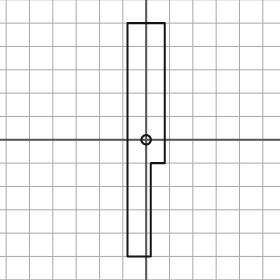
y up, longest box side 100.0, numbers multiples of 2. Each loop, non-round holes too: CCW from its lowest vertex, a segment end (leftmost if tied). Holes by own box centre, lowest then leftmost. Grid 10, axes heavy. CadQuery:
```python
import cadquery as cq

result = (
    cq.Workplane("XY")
    .moveTo(-8.0, -50.0)
    .lineTo(2.0, -50.0)
    .lineTo(2.0, -10.0)
    .lineTo(8.0, -10.0)
    .lineTo(8.0, 50.0)
    .lineTo(-8.0, 50.0)
    .close()
    .moveTo(0.0, 0.0)
    .circle(2.0)
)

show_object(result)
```